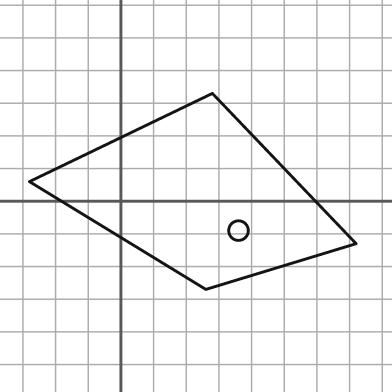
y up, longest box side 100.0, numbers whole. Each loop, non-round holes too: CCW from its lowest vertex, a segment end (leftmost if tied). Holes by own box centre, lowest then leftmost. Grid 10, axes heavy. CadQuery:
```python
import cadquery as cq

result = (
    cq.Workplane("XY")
    .moveTo(26.0, -27.0)
    .lineTo(72.0, -13.0)
    .lineTo(28.0, 33.0)
    .lineTo(-28.0, 6.0)
    .close()
    .moveTo(36.0, -9.0)
    .circle(3.0)
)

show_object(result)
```